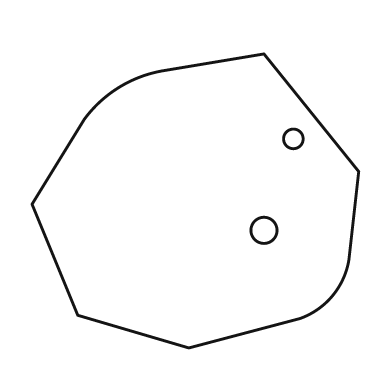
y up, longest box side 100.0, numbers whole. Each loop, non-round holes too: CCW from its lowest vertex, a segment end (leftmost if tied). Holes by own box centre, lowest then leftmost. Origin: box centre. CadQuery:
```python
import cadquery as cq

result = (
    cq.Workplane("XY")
    .moveTo(-2.0, -45.0)
    .lineTo(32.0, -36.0)
    .threePointArc((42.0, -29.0), (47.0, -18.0))
    .lineTo(50.0, 9.0)
    .lineTo(21.0, 45.0)
    .lineTo(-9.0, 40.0)
    .threePointArc((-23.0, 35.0), (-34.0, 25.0))
    .lineTo(-50.0, -1.0)
    .lineTo(-36.0, -35.0)
    .close()
    .moveTo(21.0, -9.0)
    .circle(4.0)
    .moveTo(30.0, 19.0)
    .circle(3.0)
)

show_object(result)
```